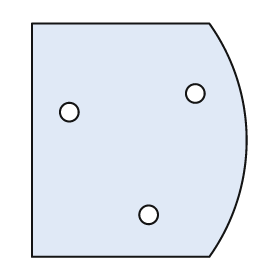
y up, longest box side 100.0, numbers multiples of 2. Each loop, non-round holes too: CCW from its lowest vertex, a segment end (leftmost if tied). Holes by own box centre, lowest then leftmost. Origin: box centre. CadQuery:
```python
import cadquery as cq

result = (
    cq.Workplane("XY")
    .moveTo(-46.0, -50.0)
    .lineTo(30.0, -50.0)
    .threePointArc((46.0, 0.0), (30.0, 50.0))
    .lineTo(-46.0, 50.0)
    .close()
    .moveTo(4.0, -32.0)
    .circle(4.0)
    .moveTo(-30.0, 12.0)
    .circle(4.0)
    .moveTo(24.0, 20.0)
    .circle(4.0)
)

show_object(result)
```